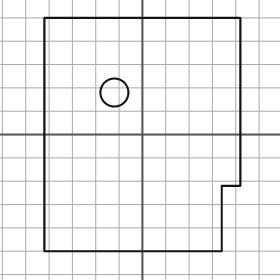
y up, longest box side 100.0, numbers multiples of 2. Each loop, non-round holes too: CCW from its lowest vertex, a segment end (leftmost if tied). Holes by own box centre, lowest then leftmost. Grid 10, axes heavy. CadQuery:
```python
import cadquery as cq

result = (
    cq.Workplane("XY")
    .moveTo(-42.0, -50.0)
    .lineTo(34.0, -50.0)
    .lineTo(34.0, -22.0)
    .lineTo(42.0, -22.0)
    .lineTo(42.0, 50.0)
    .lineTo(-42.0, 50.0)
    .close()
    .moveTo(-12.0, 18.0)
    .circle(6.0)
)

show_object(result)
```